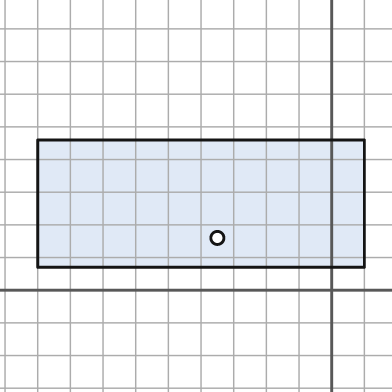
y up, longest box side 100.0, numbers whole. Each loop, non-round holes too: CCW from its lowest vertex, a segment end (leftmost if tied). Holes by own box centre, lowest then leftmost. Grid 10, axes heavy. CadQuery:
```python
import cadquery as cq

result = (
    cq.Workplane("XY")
    .moveTo(-90.0, 7.0)
    .lineTo(10.0, 7.0)
    .lineTo(10.0, 46.0)
    .lineTo(-90.0, 46.0)
    .close()
    .moveTo(-35.0, 16.0)
    .circle(2.0)
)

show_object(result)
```